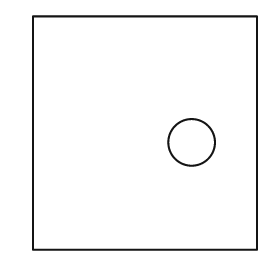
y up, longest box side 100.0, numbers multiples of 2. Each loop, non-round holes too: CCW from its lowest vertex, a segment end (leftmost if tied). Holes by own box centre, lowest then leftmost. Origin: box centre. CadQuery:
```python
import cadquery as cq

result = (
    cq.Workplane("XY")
    .moveTo(-48.0, -50.0)
    .lineTo(48.0, -50.0)
    .lineTo(48.0, 50.0)
    .lineTo(-48.0, 50.0)
    .close()
    .moveTo(20.0, -4.0)
    .circle(10.0)
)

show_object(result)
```